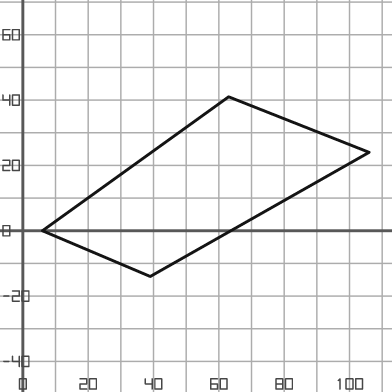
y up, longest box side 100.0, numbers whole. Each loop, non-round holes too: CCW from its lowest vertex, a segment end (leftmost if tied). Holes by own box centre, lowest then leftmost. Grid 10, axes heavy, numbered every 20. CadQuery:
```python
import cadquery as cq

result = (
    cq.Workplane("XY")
    .moveTo(39.0, -14.0)
    .lineTo(106.0, 24.0)
    .lineTo(63.0, 41.0)
    .lineTo(6.0, 0.0)
    .close()
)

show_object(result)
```